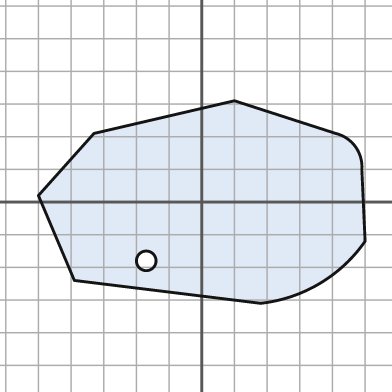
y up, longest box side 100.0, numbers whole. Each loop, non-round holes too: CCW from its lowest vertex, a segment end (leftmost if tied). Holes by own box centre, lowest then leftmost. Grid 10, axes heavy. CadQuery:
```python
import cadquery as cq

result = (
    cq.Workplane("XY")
    .moveTo(18.0, -31.0)
    .threePointArc((36.0, -25.0), (50.0, -12.0))
    .lineTo(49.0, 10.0)
    .threePointArc((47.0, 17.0), (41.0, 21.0))
    .lineTo(10.0, 31.0)
    .lineTo(-33.0, 21.0)
    .lineTo(-50.0, 2.0)
    .lineTo(-39.0, -24.0)
    .close()
    .moveTo(-17.0, -18.0)
    .circle(3.0)
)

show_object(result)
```